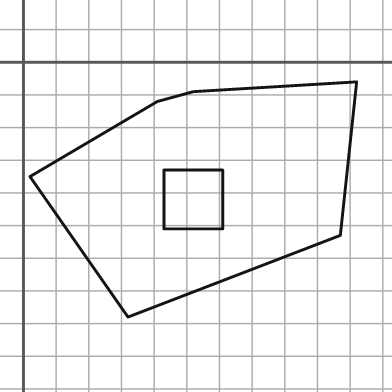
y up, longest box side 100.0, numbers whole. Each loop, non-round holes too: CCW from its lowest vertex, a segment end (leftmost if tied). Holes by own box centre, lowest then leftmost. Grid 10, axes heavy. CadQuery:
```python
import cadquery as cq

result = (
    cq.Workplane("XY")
    .moveTo(32.0, -78.0)
    .lineTo(97.0, -53.0)
    .lineTo(102.0, -6.0)
    .lineTo(52.0, -9.0)
    .lineTo(41.0, -12.0)
    .lineTo(2.0, -35.0)
    .close()
    .moveTo(43.0, -51.0)
    .lineTo(61.0, -51.0)
    .lineTo(61.0, -33.0)
    .lineTo(43.0, -33.0)
    .close()
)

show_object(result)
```